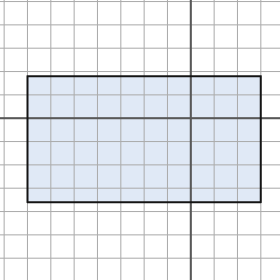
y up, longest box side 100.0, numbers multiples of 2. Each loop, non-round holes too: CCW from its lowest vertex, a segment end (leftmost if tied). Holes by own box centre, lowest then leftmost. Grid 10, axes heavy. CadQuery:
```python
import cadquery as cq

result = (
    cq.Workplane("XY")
    .moveTo(-70.0, -36.0)
    .lineTo(30.0, -36.0)
    .lineTo(30.0, 18.0)
    .lineTo(-70.0, 18.0)
    .close()
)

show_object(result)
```